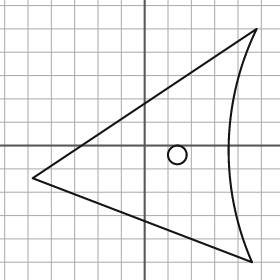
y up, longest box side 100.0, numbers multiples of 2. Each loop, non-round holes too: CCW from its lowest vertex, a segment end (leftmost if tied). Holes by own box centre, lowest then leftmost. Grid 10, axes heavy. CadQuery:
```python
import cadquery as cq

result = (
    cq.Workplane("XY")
    .moveTo(46.0, -50.0)
    .threePointArc((36.0, 0.0), (48.0, 50.0))
    .lineTo(-48.0, -14.0)
    .close()
    .moveTo(14.0, -4.0)
    .circle(4.0)
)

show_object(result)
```